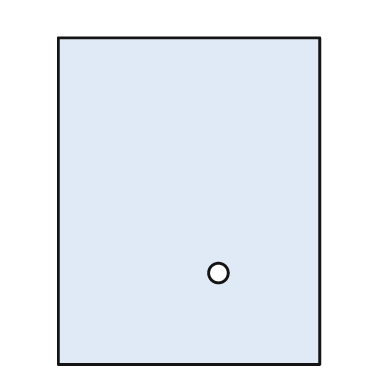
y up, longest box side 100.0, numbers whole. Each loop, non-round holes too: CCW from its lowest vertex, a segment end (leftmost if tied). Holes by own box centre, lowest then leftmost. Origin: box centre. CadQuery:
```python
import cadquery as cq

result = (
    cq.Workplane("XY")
    .moveTo(-40.0, -50.0)
    .lineTo(40.0, -50.0)
    .lineTo(40.0, 50.0)
    .lineTo(-40.0, 50.0)
    .close()
    .moveTo(9.0, -22.0)
    .circle(3.0)
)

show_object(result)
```